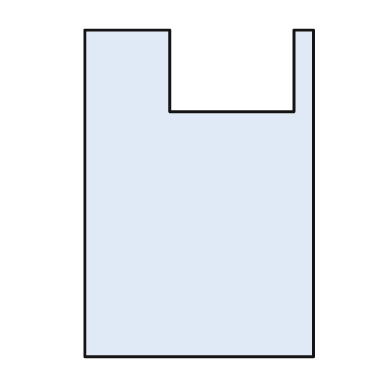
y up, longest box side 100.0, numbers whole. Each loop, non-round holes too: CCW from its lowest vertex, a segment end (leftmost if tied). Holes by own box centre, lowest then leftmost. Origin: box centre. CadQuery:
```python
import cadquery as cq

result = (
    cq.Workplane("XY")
    .moveTo(-35.0, -50.0)
    .lineTo(35.0, -50.0)
    .lineTo(35.0, 50.0)
    .lineTo(29.0, 50.0)
    .lineTo(29.0, 25.0)
    .lineTo(-9.0, 25.0)
    .lineTo(-9.0, 50.0)
    .lineTo(-35.0, 50.0)
    .close()
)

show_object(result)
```